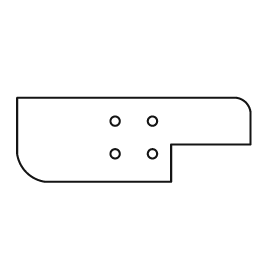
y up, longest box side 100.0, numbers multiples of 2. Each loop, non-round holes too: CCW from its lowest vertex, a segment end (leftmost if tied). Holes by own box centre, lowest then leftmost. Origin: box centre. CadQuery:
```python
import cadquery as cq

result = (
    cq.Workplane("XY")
    .moveTo(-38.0, -18.0)
    .lineTo(16.0, -18.0)
    .lineTo(16.0, -2.0)
    .lineTo(50.0, -2.0)
    .lineTo(50.0, 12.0)
    .threePointArc((48.0, 16.0), (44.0, 18.0))
    .lineTo(-50.0, 18.0)
    .lineTo(-50.0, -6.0)
    .threePointArc((-46.0, -14.0), (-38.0, -18.0))
    .close()
    .moveTo(-8.0, -6.0)
    .circle(2.0)
    .moveTo(8.0, -6.0)
    .circle(2.0)
    .moveTo(-8.0, 8.0)
    .circle(2.0)
    .moveTo(8.0, 8.0)
    .circle(2.0)
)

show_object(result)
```